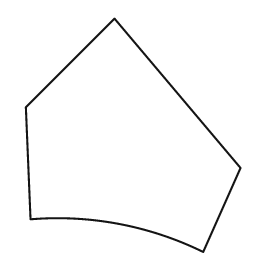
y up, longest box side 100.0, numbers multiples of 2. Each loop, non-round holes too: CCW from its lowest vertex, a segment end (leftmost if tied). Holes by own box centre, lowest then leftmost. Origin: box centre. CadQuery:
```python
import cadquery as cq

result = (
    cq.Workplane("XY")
    .moveTo(30.0, -50.0)
    .lineTo(46.0, -14.0)
    .lineTo(-8.0, 50.0)
    .lineTo(-46.0, 12.0)
    .lineTo(-44.0, -36.0)
    .threePointArc((-6.0, -38.0), (30.0, -50.0))
    .close()
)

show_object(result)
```